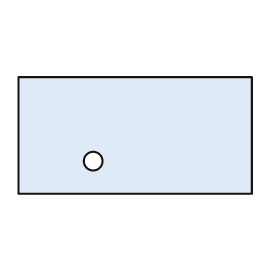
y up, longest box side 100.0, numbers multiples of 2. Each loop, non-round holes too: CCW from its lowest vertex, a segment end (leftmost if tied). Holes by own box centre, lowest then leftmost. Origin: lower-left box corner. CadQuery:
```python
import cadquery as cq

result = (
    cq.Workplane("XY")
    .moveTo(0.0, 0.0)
    .lineTo(100.0, 0.0)
    .lineTo(100.0, 50.0)
    .lineTo(0.0, 50.0)
    .close()
    .moveTo(32.0, 14.0)
    .circle(4.0)
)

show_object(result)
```